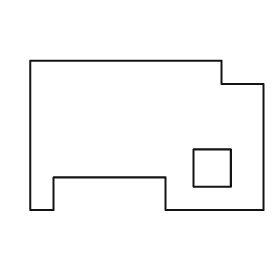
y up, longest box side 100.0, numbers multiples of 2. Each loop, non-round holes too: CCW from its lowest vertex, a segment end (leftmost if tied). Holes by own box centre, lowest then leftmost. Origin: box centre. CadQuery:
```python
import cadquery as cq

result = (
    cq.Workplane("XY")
    .moveTo(-50.0, -32.0)
    .lineTo(-40.0, -32.0)
    .lineTo(-40.0, -18.0)
    .lineTo(8.0, -18.0)
    .lineTo(8.0, -32.0)
    .lineTo(50.0, -32.0)
    .lineTo(50.0, 22.0)
    .lineTo(32.0, 22.0)
    .lineTo(32.0, 32.0)
    .lineTo(-50.0, 32.0)
    .close()
    .moveTo(20.0, -22.0)
    .lineTo(36.0, -22.0)
    .lineTo(36.0, -6.0)
    .lineTo(20.0, -6.0)
    .close()
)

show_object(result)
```